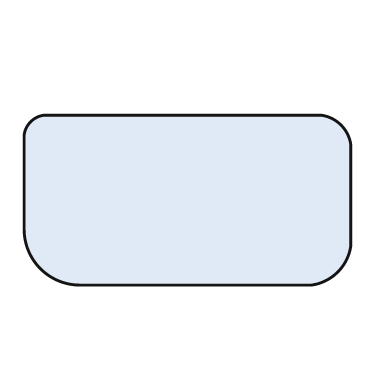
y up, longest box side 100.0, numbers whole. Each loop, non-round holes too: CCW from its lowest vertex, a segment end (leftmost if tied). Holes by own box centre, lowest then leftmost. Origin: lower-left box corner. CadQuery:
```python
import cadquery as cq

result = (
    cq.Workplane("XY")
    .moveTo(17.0, 0.0)
    .lineTo(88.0, 0.0)
    .threePointArc((96.0, 4.0), (100.0, 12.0))
    .lineTo(100.0, 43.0)
    .threePointArc((97.0, 49.0), (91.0, 52.0))
    .lineTo(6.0, 52.0)
    .threePointArc((2.0, 50.0), (0.0, 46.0))
    .lineTo(0.0, 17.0)
    .threePointArc((5.0, 5.0), (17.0, 0.0))
    .close()
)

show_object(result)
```